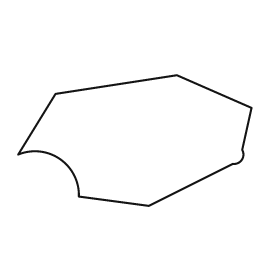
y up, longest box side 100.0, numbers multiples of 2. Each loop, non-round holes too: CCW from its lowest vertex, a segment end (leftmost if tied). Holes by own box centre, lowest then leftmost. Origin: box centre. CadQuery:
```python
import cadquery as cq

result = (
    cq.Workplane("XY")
    .moveTo(6.0, -28.0)
    .lineTo(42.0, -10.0)
    .threePointArc((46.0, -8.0), (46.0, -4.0))
    .lineTo(50.0, 14.0)
    .lineTo(18.0, 28.0)
    .lineTo(-34.0, 20.0)
    .lineTo(-50.0, -6.0)
    .threePointArc((-32.0, -8.0), (-24.0, -24.0))
    .close()
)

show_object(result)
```